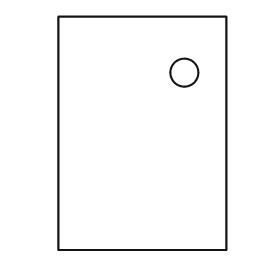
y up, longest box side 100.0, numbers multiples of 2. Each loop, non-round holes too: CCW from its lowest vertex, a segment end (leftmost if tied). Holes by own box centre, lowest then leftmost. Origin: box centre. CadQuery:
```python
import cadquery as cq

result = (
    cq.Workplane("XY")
    .moveTo(-36.0, -50.0)
    .lineTo(36.0, -50.0)
    .lineTo(36.0, 50.0)
    .lineTo(-36.0, 50.0)
    .close()
    .moveTo(18.0, 26.0)
    .circle(6.0)
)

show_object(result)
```